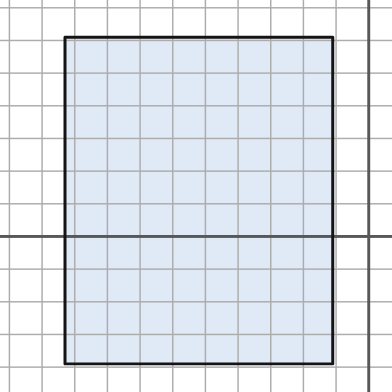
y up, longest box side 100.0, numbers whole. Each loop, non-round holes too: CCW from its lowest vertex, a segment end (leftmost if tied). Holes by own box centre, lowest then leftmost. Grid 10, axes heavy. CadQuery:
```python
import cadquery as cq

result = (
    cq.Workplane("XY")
    .moveTo(-93.0, -39.0)
    .lineTo(-11.0, -39.0)
    .lineTo(-11.0, 61.0)
    .lineTo(-93.0, 61.0)
    .close()
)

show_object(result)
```